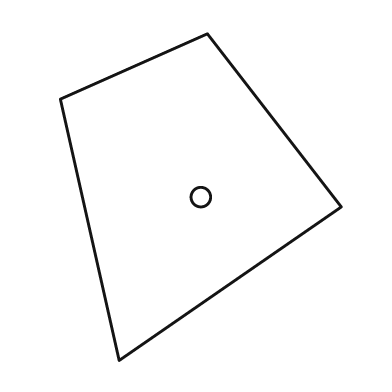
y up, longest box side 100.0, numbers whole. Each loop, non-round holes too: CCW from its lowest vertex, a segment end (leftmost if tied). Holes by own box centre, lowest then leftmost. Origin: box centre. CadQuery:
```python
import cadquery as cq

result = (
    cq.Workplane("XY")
    .moveTo(-25.0, -50.0)
    .lineTo(43.0, -3.0)
    .lineTo(2.0, 50.0)
    .lineTo(-43.0, 30.0)
    .close()
    .moveTo(0.0, 0.0)
    .circle(3.0)
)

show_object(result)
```